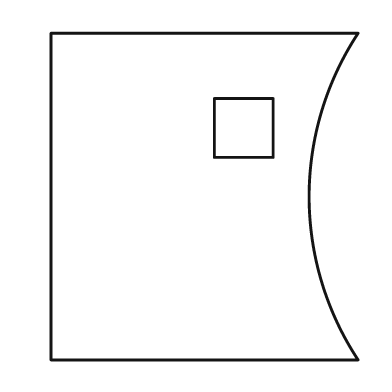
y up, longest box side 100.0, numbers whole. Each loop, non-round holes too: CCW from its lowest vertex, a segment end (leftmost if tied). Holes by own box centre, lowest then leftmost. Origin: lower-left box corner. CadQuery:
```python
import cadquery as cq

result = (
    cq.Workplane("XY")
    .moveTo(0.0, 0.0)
    .lineTo(94.0, 0.0)
    .threePointArc((79.0, 50.0), (94.0, 100.0))
    .lineTo(0.0, 100.0)
    .close()
    .moveTo(50.0, 62.0)
    .lineTo(68.0, 62.0)
    .lineTo(68.0, 80.0)
    .lineTo(50.0, 80.0)
    .close()
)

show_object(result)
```